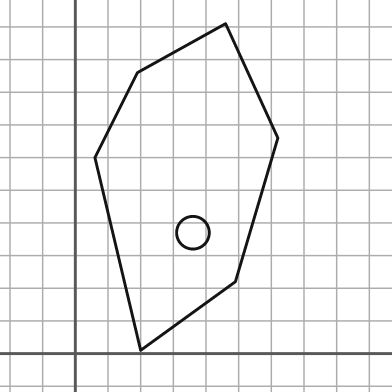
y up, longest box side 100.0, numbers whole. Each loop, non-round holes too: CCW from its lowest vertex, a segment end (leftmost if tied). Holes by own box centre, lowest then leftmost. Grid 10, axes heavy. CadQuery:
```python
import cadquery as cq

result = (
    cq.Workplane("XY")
    .moveTo(20.0, 1.0)
    .lineTo(49.0, 22.0)
    .lineTo(62.0, 66.0)
    .lineTo(46.0, 101.0)
    .lineTo(19.0, 86.0)
    .lineTo(6.0, 60.0)
    .close()
    .moveTo(36.0, 37.0)
    .circle(5.0)
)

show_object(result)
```